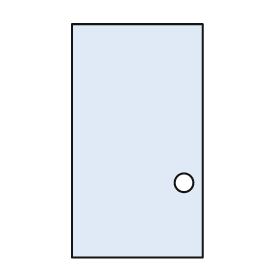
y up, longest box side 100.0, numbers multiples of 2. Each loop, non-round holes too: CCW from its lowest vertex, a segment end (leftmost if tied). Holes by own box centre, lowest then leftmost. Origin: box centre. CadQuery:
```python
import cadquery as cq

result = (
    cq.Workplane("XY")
    .moveTo(-28.0, -50.0)
    .lineTo(28.0, -50.0)
    .lineTo(28.0, 50.0)
    .lineTo(-28.0, 50.0)
    .close()
    .moveTo(20.0, -18.0)
    .circle(4.0)
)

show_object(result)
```